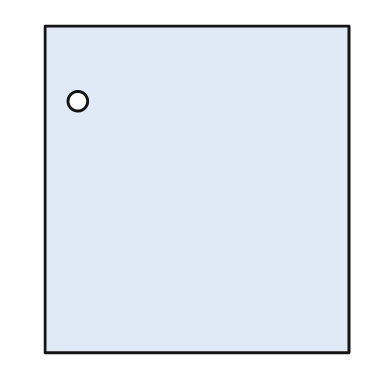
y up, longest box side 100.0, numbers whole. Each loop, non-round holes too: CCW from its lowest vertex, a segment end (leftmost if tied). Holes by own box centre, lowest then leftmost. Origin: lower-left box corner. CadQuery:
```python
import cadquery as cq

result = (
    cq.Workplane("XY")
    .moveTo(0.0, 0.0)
    .lineTo(93.0, 0.0)
    .lineTo(93.0, 100.0)
    .lineTo(0.0, 100.0)
    .close()
    .moveTo(10.0, 77.0)
    .circle(3.0)
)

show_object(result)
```